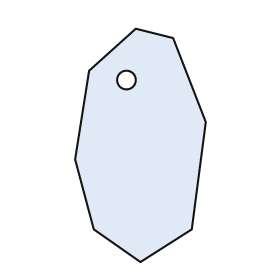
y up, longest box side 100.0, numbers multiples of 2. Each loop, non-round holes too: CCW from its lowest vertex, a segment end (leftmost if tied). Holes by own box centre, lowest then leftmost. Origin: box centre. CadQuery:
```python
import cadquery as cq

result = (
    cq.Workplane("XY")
    .moveTo(0.0, -50.0)
    .lineTo(22.0, -36.0)
    .lineTo(28.0, 10.0)
    .lineTo(14.0, 46.0)
    .lineTo(-2.0, 50.0)
    .lineTo(-22.0, 32.0)
    .lineTo(-28.0, -6.0)
    .lineTo(-20.0, -36.0)
    .close()
    .moveTo(-6.0, 28.0)
    .circle(4.0)
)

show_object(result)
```